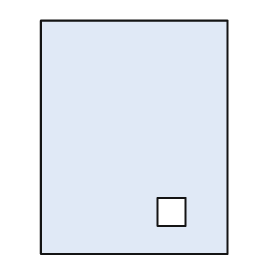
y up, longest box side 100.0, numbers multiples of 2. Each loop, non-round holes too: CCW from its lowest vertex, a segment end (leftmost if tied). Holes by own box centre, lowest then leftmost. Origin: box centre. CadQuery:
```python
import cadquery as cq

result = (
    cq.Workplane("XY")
    .moveTo(-40.0, -50.0)
    .lineTo(40.0, -50.0)
    .lineTo(40.0, 50.0)
    .lineTo(-40.0, 50.0)
    .close()
    .moveTo(10.0, -38.0)
    .lineTo(22.0, -38.0)
    .lineTo(22.0, -26.0)
    .lineTo(10.0, -26.0)
    .close()
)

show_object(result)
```